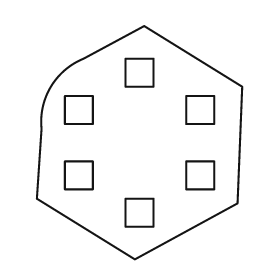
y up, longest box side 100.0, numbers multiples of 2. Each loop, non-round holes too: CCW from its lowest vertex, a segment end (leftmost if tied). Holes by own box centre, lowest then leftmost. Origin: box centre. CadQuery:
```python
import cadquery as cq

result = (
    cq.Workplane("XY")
    .moveTo(-2.0, -50.0)
    .lineTo(42.0, -26.0)
    .lineTo(44.0, 24.0)
    .lineTo(2.0, 50.0)
    .lineTo(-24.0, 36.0)
    .threePointArc((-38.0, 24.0), (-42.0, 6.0))
    .lineTo(-44.0, -24.0)
    .close()
    .moveTo(-6.0, -36.0)
    .lineTo(6.0, -36.0)
    .lineTo(6.0, -24.0)
    .lineTo(-6.0, -24.0)
    .close()
    .moveTo(-32.0, -20.0)
    .lineTo(-20.0, -20.0)
    .lineTo(-20.0, -8.0)
    .lineTo(-32.0, -8.0)
    .close()
    .moveTo(20.0, -20.0)
    .lineTo(32.0, -20.0)
    .lineTo(32.0, -8.0)
    .lineTo(20.0, -8.0)
    .close()
    .moveTo(-32.0, 8.0)
    .lineTo(-20.0, 8.0)
    .lineTo(-20.0, 20.0)
    .lineTo(-32.0, 20.0)
    .close()
    .moveTo(20.0, 8.0)
    .lineTo(32.0, 8.0)
    .lineTo(32.0, 20.0)
    .lineTo(20.0, 20.0)
    .close()
    .moveTo(-6.0, 24.0)
    .lineTo(6.0, 24.0)
    .lineTo(6.0, 36.0)
    .lineTo(-6.0, 36.0)
    .close()
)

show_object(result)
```